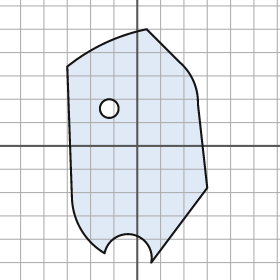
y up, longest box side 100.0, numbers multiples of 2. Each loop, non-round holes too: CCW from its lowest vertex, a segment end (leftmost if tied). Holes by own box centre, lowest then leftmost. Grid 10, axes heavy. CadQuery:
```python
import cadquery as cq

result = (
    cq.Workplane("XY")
    .moveTo(6.0, -50.0)
    .lineTo(30.0, -18.0)
    .lineTo(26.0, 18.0)
    .threePointArc((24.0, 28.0), (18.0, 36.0))
    .lineTo(4.0, 50.0)
    .threePointArc((-14.0, 44.0), (-30.0, 34.0))
    .lineTo(-28.0, -22.0)
    .threePointArc((-24.0, -36.0), (-14.0, -46.0))
    .threePointArc((-2.0, -38.0), (6.0, -50.0))
    .close()
    .moveTo(-12.0, 16.0)
    .circle(4.0)
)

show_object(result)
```